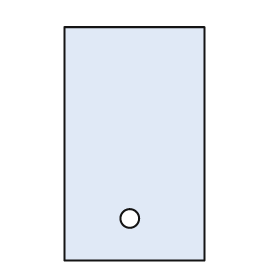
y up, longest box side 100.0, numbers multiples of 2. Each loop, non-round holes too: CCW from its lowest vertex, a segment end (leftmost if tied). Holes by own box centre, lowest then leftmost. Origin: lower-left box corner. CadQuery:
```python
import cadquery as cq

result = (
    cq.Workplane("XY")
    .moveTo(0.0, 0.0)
    .lineTo(60.0, 0.0)
    .lineTo(60.0, 100.0)
    .lineTo(0.0, 100.0)
    .close()
    .moveTo(28.0, 18.0)
    .circle(4.0)
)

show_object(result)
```